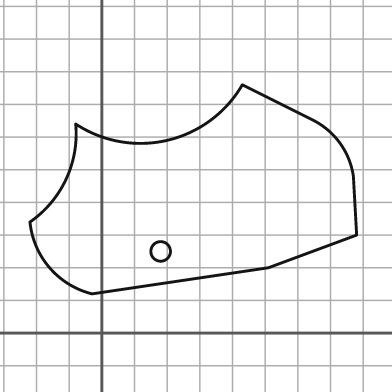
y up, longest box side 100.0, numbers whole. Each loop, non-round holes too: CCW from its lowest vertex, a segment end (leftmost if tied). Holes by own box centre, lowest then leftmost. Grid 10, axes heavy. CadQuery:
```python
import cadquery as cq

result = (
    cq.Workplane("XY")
    .moveTo(-3.0, 12.0)
    .lineTo(51.0, 20.0)
    .lineTo(78.0, 30.0)
    .lineTo(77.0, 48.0)
    .threePointArc((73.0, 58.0), (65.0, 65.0))
    .lineTo(43.0, 76.0)
    .threePointArc((20.0, 59.0), (-8.0, 64.0))
    .threePointArc((-11.0, 47.0), (-22.0, 34.0))
    .threePointArc((-16.0, 20.0), (-3.0, 12.0))
    .close()
    .moveTo(18.0, 25.0)
    .circle(3.0)
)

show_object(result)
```